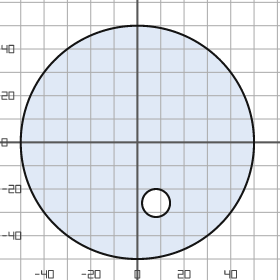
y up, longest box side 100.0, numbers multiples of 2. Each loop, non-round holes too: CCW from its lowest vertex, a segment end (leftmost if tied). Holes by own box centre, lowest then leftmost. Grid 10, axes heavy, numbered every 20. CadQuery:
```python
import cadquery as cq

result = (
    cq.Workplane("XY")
    .moveTo(0.0, 0.0)
    .circle(50.0)
    .moveTo(8.0, -26.0)
    .circle(6.0)
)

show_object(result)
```